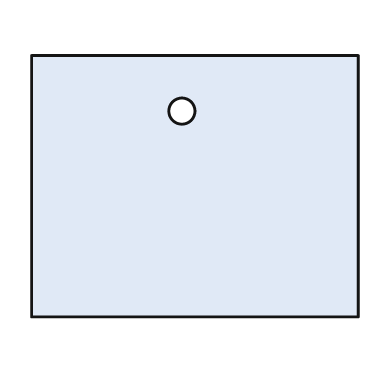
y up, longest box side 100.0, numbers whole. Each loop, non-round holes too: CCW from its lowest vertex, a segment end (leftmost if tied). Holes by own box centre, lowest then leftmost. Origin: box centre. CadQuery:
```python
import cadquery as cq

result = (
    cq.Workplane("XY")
    .moveTo(-50.0, -40.0)
    .lineTo(50.0, -40.0)
    .lineTo(50.0, 40.0)
    .lineTo(-50.0, 40.0)
    .close()
    .moveTo(-4.0, 23.0)
    .circle(4.0)
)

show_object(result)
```